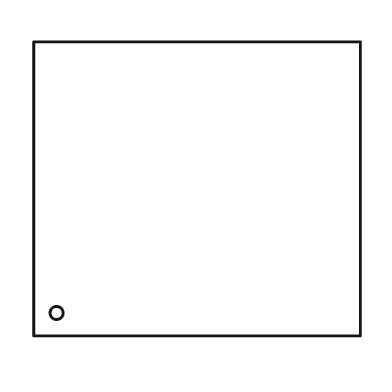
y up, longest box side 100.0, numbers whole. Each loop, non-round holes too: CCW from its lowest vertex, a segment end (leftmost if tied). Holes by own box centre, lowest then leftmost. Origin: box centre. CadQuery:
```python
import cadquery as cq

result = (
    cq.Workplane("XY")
    .moveTo(-50.0, -45.0)
    .lineTo(50.0, -45.0)
    .lineTo(50.0, 45.0)
    .lineTo(-50.0, 45.0)
    .close()
    .moveTo(-43.0, -38.0)
    .circle(2.0)
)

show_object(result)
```